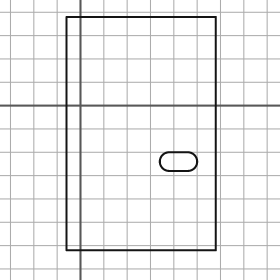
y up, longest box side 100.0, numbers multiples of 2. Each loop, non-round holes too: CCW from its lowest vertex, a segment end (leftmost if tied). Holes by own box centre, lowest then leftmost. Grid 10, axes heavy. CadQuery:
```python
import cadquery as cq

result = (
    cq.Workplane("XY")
    .moveTo(-6.0, -62.0)
    .lineTo(58.0, -62.0)
    .lineTo(58.0, 38.0)
    .lineTo(-6.0, 38.0)
    .close()
    .moveTo(38.0, -28.0)
    .lineTo(46.0, -28.0)
    .threePointArc((50.0, -24.0), (46.0, -20.0))
    .lineTo(38.0, -20.0)
    .threePointArc((34.0, -24.0), (38.0, -28.0))
    .close()
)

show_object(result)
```